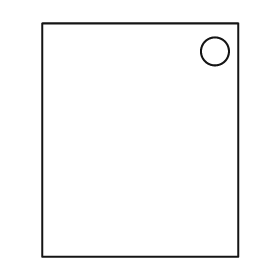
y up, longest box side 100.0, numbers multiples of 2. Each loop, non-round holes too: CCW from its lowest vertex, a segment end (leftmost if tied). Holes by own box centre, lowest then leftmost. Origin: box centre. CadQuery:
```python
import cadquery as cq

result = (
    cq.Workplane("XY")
    .moveTo(-42.0, -50.0)
    .lineTo(42.0, -50.0)
    .lineTo(42.0, 50.0)
    .lineTo(-42.0, 50.0)
    .close()
    .moveTo(32.0, 38.0)
    .circle(6.0)
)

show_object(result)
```